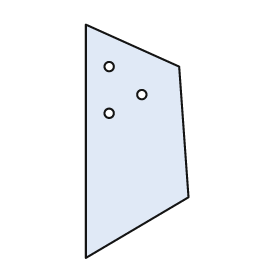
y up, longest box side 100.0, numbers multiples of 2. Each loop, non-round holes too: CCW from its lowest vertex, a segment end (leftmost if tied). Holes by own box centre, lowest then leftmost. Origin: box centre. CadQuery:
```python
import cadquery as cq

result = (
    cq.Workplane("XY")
    .moveTo(-22.0, -50.0)
    .lineTo(22.0, -24.0)
    .lineTo(18.0, 32.0)
    .lineTo(-22.0, 50.0)
    .close()
    .moveTo(-12.0, 12.0)
    .circle(2.0)
    .moveTo(2.0, 20.0)
    .circle(2.0)
    .moveTo(-12.0, 32.0)
    .circle(2.0)
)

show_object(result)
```